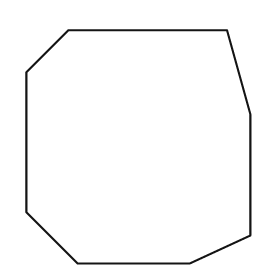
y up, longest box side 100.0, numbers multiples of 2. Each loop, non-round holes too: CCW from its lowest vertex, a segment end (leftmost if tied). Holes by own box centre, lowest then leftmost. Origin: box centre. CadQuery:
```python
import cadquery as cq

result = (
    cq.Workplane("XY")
    .moveTo(-26.0, -50.0)
    .lineTo(22.0, -50.0)
    .lineTo(48.0, -38.0)
    .lineTo(48.0, 14.0)
    .lineTo(38.0, 50.0)
    .lineTo(-30.0, 50.0)
    .lineTo(-48.0, 32.0)
    .lineTo(-48.0, -28.0)
    .close()
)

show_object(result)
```